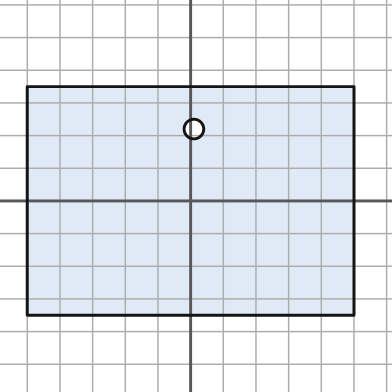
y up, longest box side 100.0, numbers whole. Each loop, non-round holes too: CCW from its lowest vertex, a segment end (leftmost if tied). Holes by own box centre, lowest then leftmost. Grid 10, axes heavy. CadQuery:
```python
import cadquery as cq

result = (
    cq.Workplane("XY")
    .moveTo(-50.0, -35.0)
    .lineTo(50.0, -35.0)
    .lineTo(50.0, 35.0)
    .lineTo(-50.0, 35.0)
    .close()
    .moveTo(1.0, 22.0)
    .circle(3.0)
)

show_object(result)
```